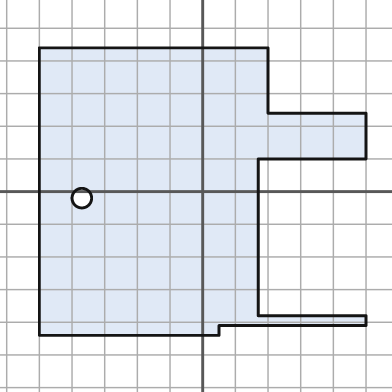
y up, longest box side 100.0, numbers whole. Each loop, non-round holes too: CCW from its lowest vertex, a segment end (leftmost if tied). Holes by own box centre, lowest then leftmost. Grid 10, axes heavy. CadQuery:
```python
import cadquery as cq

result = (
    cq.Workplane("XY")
    .moveTo(-50.0, -44.0)
    .lineTo(5.0, -44.0)
    .lineTo(5.0, -41.0)
    .lineTo(50.0, -41.0)
    .lineTo(50.0, -38.0)
    .lineTo(17.0, -38.0)
    .lineTo(17.0, 10.0)
    .lineTo(50.0, 10.0)
    .lineTo(50.0, 24.0)
    .lineTo(20.0, 24.0)
    .lineTo(20.0, 44.0)
    .lineTo(-50.0, 44.0)
    .close()
    .moveTo(-37.0, -2.0)
    .circle(3.0)
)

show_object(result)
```